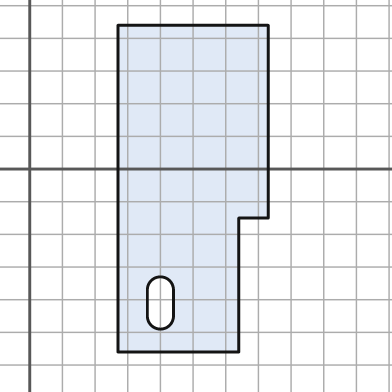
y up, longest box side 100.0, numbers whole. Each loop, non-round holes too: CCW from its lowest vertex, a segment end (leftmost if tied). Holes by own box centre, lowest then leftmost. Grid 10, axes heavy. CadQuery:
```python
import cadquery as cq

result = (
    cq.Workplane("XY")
    .moveTo(27.0, -56.0)
    .lineTo(64.0, -56.0)
    .lineTo(64.0, -15.0)
    .lineTo(73.0, -15.0)
    .lineTo(73.0, 44.0)
    .lineTo(27.0, 44.0)
    .close()
    .moveTo(36.0, -45.0)
    .threePointArc((40.0, -49.0), (44.0, -45.0))
    .lineTo(44.0, -37.0)
    .threePointArc((40.0, -33.0), (36.0, -37.0))
    .close()
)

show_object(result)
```